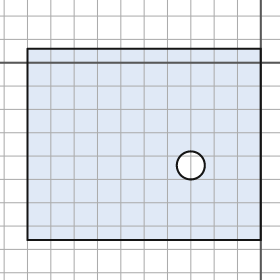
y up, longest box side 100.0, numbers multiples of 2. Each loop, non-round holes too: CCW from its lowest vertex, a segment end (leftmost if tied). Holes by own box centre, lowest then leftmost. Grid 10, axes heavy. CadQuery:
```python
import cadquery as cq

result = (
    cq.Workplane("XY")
    .moveTo(-100.0, -76.0)
    .lineTo(0.0, -76.0)
    .lineTo(0.0, 6.0)
    .lineTo(-100.0, 6.0)
    .close()
    .moveTo(-30.0, -44.0)
    .circle(6.0)
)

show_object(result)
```